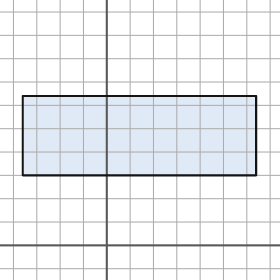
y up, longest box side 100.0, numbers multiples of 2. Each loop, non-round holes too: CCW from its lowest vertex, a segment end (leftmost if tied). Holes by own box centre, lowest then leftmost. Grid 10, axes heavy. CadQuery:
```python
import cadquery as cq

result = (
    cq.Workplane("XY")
    .moveTo(-36.0, 30.0)
    .lineTo(64.0, 30.0)
    .lineTo(64.0, 64.0)
    .lineTo(-36.0, 64.0)
    .close()
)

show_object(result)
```